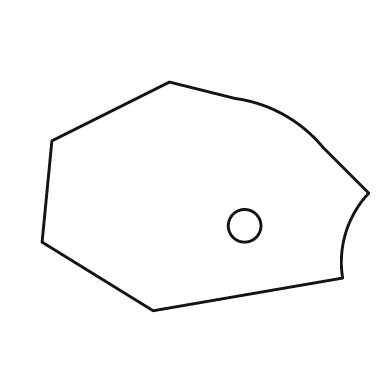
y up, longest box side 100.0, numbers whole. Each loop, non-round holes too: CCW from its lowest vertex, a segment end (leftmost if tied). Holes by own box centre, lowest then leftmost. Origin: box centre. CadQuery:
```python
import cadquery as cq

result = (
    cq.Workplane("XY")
    .moveTo(-16.0, -35.0)
    .lineTo(42.0, -25.0)
    .threePointArc((43.0, -11.0), (50.0, 1.0))
    .lineTo(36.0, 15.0)
    .threePointArc((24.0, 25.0), (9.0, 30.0))
    .lineTo(-11.0, 35.0)
    .lineTo(-47.0, 17.0)
    .lineTo(-50.0, -14.0)
    .close()
    .moveTo(12.0, -9.0)
    .circle(5.0)
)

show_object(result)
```